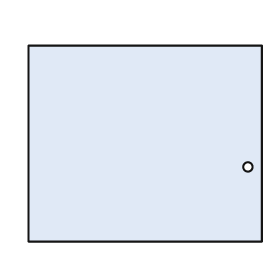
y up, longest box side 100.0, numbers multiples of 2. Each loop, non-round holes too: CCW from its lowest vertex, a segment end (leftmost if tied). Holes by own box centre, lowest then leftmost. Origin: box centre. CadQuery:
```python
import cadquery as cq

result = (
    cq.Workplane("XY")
    .moveTo(-50.0, -42.0)
    .lineTo(50.0, -42.0)
    .lineTo(50.0, 42.0)
    .lineTo(-50.0, 42.0)
    .close()
    .moveTo(44.0, -10.0)
    .circle(2.0)
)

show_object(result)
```